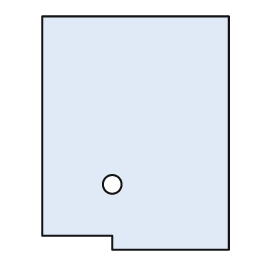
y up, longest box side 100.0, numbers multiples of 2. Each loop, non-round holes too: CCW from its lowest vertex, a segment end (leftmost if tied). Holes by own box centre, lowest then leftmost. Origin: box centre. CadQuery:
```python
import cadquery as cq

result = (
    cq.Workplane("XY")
    .moveTo(-10.0, -50.0)
    .lineTo(40.0, -50.0)
    .lineTo(40.0, 50.0)
    .lineTo(-40.0, 50.0)
    .lineTo(-40.0, -44.0)
    .lineTo(-10.0, -44.0)
    .close()
    .moveTo(-10.0, -22.0)
    .circle(4.0)
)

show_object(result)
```